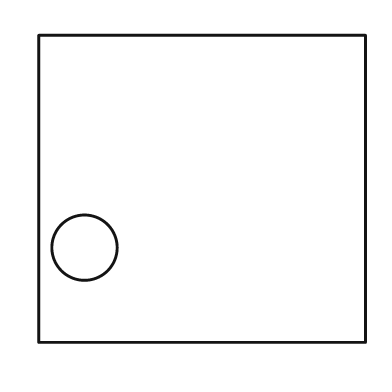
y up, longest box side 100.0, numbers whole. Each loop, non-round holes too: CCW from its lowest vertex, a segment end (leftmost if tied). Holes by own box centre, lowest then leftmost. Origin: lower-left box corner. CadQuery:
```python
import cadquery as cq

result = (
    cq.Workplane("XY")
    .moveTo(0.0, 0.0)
    .lineTo(100.0, 0.0)
    .lineTo(100.0, 94.0)
    .lineTo(0.0, 94.0)
    .close()
    .moveTo(14.0, 29.0)
    .circle(10.0)
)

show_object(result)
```